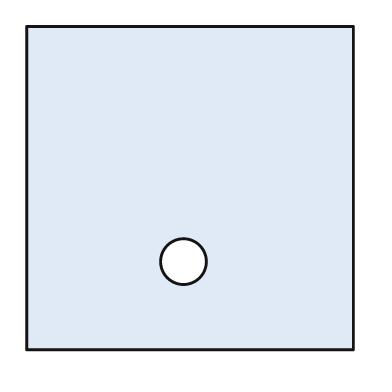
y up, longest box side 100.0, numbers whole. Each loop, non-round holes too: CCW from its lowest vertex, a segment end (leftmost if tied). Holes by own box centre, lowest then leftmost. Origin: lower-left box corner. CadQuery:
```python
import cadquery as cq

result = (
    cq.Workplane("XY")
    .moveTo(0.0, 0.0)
    .lineTo(100.0, 0.0)
    .lineTo(100.0, 99.0)
    .lineTo(0.0, 99.0)
    .close()
    .moveTo(48.0, 27.0)
    .circle(7.0)
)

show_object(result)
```